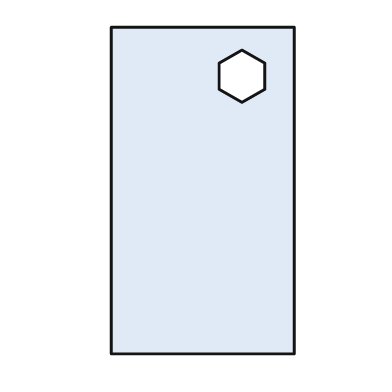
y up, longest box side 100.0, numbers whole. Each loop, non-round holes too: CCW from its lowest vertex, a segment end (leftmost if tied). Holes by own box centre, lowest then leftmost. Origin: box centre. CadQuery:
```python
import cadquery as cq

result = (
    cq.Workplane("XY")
    .moveTo(-28.0, -50.0)
    .lineTo(28.0, -50.0)
    .lineTo(28.0, 50.0)
    .lineTo(-28.0, 50.0)
    .close()
    .moveTo(12.0, 27.0)
    .lineTo(19.0, 31.0)
    .lineTo(19.0, 39.0)
    .lineTo(12.0, 43.0)
    .lineTo(5.0, 39.0)
    .lineTo(5.0, 31.0)
    .close()
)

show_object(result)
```